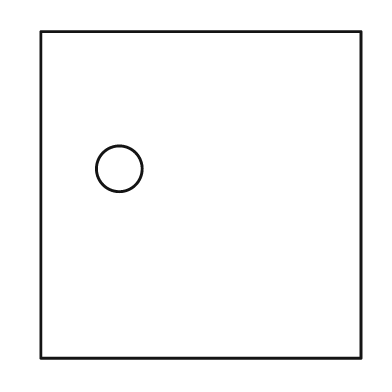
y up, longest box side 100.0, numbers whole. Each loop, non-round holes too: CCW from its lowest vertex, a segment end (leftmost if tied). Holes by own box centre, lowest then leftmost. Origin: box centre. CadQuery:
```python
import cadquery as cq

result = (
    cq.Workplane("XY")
    .moveTo(-49.0, -50.0)
    .lineTo(49.0, -50.0)
    .lineTo(49.0, 50.0)
    .lineTo(-49.0, 50.0)
    .close()
    .moveTo(-25.0, 8.0)
    .circle(7.0)
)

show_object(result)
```